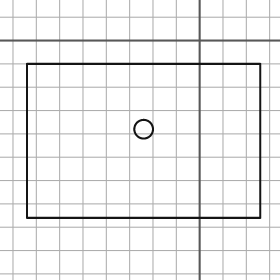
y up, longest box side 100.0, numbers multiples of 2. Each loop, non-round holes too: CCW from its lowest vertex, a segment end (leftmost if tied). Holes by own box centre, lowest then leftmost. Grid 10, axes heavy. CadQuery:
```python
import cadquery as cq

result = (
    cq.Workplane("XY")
    .moveTo(-74.0, -76.0)
    .lineTo(26.0, -76.0)
    .lineTo(26.0, -10.0)
    .lineTo(-74.0, -10.0)
    .close()
    .moveTo(-24.0, -38.0)
    .circle(4.0)
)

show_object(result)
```